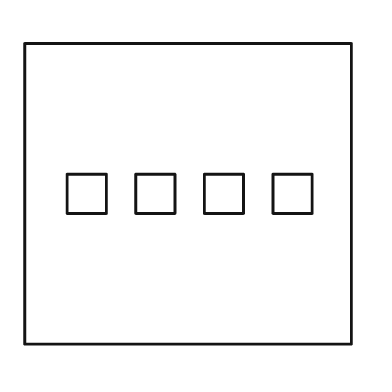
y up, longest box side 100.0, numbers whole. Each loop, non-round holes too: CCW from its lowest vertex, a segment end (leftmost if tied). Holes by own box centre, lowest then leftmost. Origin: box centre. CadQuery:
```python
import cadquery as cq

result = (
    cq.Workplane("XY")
    .moveTo(-50.0, -46.0)
    .lineTo(50.0, -46.0)
    .lineTo(50.0, 46.0)
    .lineTo(-50.0, 46.0)
    .close()
    .moveTo(-37.0, -6.0)
    .lineTo(-25.0, -6.0)
    .lineTo(-25.0, 6.0)
    .lineTo(-37.0, 6.0)
    .close()
    .moveTo(-16.0, -6.0)
    .lineTo(-4.0, -6.0)
    .lineTo(-4.0, 6.0)
    .lineTo(-16.0, 6.0)
    .close()
    .moveTo(5.0, -6.0)
    .lineTo(17.0, -6.0)
    .lineTo(17.0, 6.0)
    .lineTo(5.0, 6.0)
    .close()
    .moveTo(26.0, -6.0)
    .lineTo(38.0, -6.0)
    .lineTo(38.0, 6.0)
    .lineTo(26.0, 6.0)
    .close()
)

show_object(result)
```